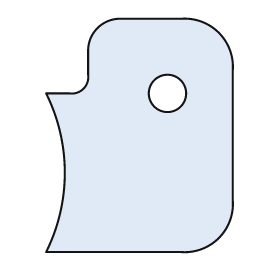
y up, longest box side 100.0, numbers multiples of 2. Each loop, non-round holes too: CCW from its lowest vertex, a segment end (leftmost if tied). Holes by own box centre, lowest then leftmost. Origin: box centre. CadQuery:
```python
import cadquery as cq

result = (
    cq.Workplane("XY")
    .moveTo(-40.0, -50.0)
    .lineTo(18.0, -50.0)
    .threePointArc((34.0, -44.0), (40.0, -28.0))
    .lineTo(40.0, 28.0)
    .threePointArc((34.0, 44.0), (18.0, 50.0))
    .lineTo(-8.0, 50.0)
    .threePointArc((-18.0, 46.0), (-22.0, 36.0))
    .lineTo(-22.0, 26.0)
    .threePointArc((-24.0, 20.0), (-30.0, 18.0))
    .lineTo(-40.0, 18.0)
    .threePointArc((-32.0, -16.0), (-40.0, -50.0))
    .close()
    .moveTo(12.0, 18.0)
    .circle(8.0)
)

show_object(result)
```